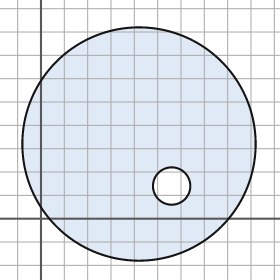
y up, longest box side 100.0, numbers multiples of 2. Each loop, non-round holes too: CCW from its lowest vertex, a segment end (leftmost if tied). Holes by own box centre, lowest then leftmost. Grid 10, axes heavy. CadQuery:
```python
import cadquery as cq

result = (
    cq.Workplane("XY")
    .moveTo(42.0, 32.0)
    .circle(50.0)
    .moveTo(56.0, 14.0)
    .circle(8.0)
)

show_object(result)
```